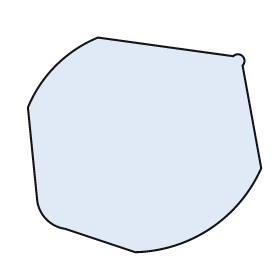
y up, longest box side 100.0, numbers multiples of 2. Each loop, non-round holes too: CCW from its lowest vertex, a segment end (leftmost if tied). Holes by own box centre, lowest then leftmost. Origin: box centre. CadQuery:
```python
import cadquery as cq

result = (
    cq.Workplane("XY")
    .moveTo(-4.0, -46.0)
    .threePointArc((28.0, -36.0), (50.0, -10.0))
    .lineTo(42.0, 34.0)
    .threePointArc((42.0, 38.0), (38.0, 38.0))
    .lineTo(-20.0, 46.0)
    .threePointArc((-38.0, 34.0), (-50.0, 16.0))
    .lineTo(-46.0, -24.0)
    .threePointArc((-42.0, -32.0), (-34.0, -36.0))
    .close()
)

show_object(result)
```